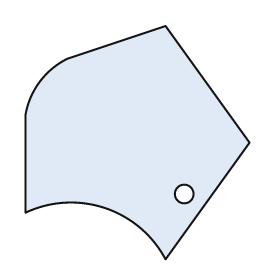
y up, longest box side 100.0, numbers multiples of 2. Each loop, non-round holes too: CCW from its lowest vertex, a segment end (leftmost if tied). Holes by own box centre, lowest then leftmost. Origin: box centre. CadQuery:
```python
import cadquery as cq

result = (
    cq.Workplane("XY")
    .moveTo(12.0, -50.0)
    .lineTo(48.0, 0.0)
    .lineTo(12.0, 50.0)
    .lineTo(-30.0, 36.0)
    .threePointArc((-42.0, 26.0), (-48.0, 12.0))
    .lineTo(-48.0, -30.0)
    .threePointArc((-14.0, -28.0), (12.0, -50.0))
    .close()
    .moveTo(20.0, -22.0)
    .circle(4.0)
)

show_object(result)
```